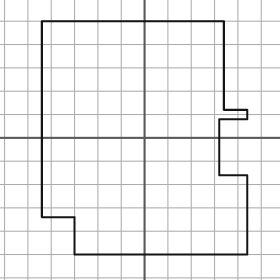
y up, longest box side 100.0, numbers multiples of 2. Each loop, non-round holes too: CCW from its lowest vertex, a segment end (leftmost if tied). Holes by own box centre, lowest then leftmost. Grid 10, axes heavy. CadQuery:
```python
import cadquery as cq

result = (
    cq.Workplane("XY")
    .moveTo(-30.0, -50.0)
    .lineTo(44.0, -50.0)
    .lineTo(44.0, -16.0)
    .lineTo(32.0, -16.0)
    .lineTo(32.0, 8.0)
    .lineTo(44.0, 8.0)
    .lineTo(44.0, 12.0)
    .lineTo(34.0, 12.0)
    .lineTo(34.0, 50.0)
    .lineTo(-44.0, 50.0)
    .lineTo(-44.0, -34.0)
    .lineTo(-30.0, -34.0)
    .close()
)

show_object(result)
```